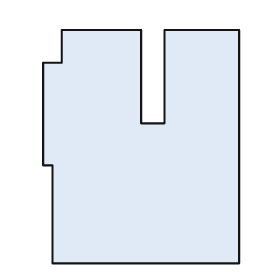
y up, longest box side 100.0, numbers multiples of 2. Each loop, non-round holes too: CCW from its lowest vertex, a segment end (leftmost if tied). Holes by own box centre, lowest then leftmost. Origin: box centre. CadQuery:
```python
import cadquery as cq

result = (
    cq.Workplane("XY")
    .moveTo(-38.0, -50.0)
    .lineTo(42.0, -50.0)
    .lineTo(42.0, 50.0)
    .lineTo(10.0, 50.0)
    .lineTo(10.0, 10.0)
    .lineTo(0.0, 10.0)
    .lineTo(0.0, 50.0)
    .lineTo(-34.0, 50.0)
    .lineTo(-34.0, 36.0)
    .lineTo(-42.0, 36.0)
    .lineTo(-42.0, -8.0)
    .lineTo(-38.0, -8.0)
    .close()
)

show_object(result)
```